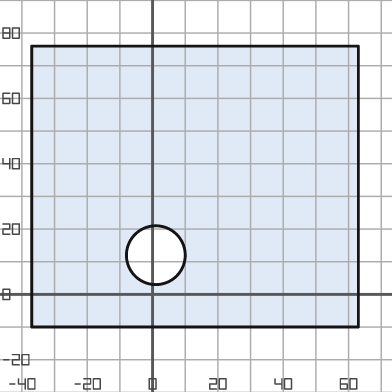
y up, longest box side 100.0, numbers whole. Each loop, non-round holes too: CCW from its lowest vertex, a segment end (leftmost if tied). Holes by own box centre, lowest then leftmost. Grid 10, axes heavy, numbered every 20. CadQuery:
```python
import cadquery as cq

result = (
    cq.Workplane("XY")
    .moveTo(-37.0, -10.0)
    .lineTo(63.0, -10.0)
    .lineTo(63.0, 76.0)
    .lineTo(-37.0, 76.0)
    .close()
    .moveTo(1.0, 12.0)
    .circle(9.0)
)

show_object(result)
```